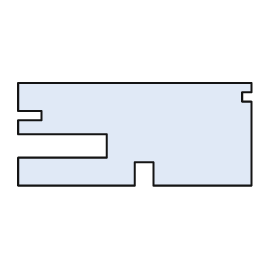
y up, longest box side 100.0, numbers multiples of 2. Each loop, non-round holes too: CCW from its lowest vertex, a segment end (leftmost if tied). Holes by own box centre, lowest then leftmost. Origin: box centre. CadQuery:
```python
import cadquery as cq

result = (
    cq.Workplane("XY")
    .moveTo(-50.0, -22.0)
    .lineTo(0.0, -22.0)
    .lineTo(0.0, -12.0)
    .lineTo(8.0, -12.0)
    .lineTo(8.0, -22.0)
    .lineTo(50.0, -22.0)
    .lineTo(50.0, 14.0)
    .lineTo(46.0, 14.0)
    .lineTo(46.0, 18.0)
    .lineTo(50.0, 18.0)
    .lineTo(50.0, 22.0)
    .lineTo(-50.0, 22.0)
    .lineTo(-50.0, 10.0)
    .lineTo(-40.0, 10.0)
    .lineTo(-40.0, 6.0)
    .lineTo(-50.0, 6.0)
    .lineTo(-50.0, 0.0)
    .lineTo(-12.0, 0.0)
    .lineTo(-12.0, -10.0)
    .lineTo(-50.0, -10.0)
    .close()
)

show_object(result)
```